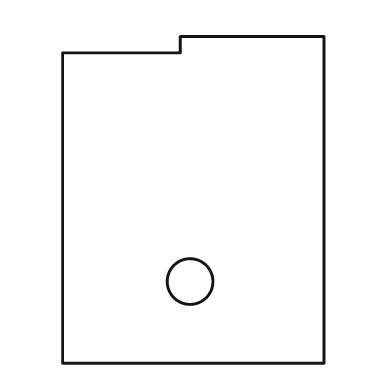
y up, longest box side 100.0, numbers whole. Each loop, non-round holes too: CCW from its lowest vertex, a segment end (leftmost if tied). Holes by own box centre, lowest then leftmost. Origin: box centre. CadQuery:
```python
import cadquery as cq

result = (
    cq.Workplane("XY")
    .moveTo(-40.0, -50.0)
    .lineTo(40.0, -50.0)
    .lineTo(40.0, 50.0)
    .lineTo(-4.0, 50.0)
    .lineTo(-4.0, 45.0)
    .lineTo(-40.0, 45.0)
    .close()
    .moveTo(-1.0, -25.0)
    .circle(7.0)
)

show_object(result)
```